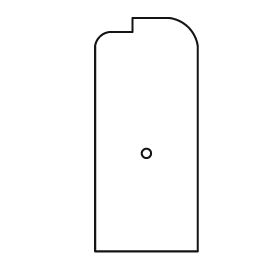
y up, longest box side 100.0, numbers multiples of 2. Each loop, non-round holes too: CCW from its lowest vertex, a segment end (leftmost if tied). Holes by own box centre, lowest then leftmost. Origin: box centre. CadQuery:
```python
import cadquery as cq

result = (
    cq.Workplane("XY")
    .moveTo(-22.0, -50.0)
    .lineTo(22.0, -50.0)
    .lineTo(22.0, 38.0)
    .threePointArc((18.0, 46.0), (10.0, 50.0))
    .lineTo(-6.0, 50.0)
    .lineTo(-6.0, 44.0)
    .lineTo(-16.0, 44.0)
    .threePointArc((-20.0, 42.0), (-22.0, 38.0))
    .close()
    .moveTo(0.0, -8.0)
    .circle(2.0)
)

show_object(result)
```